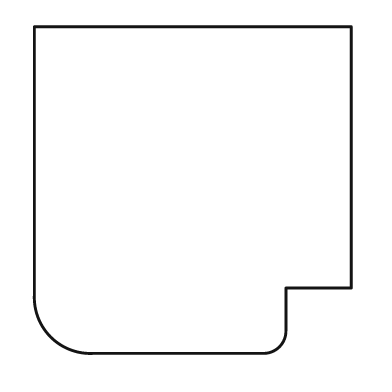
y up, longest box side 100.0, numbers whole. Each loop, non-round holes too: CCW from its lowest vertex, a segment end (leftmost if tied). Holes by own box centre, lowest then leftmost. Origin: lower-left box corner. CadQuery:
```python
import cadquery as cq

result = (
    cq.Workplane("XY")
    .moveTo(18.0, 0.0)
    .lineTo(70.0, 0.0)
    .threePointArc((75.0, 2.0), (77.0, 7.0))
    .lineTo(77.0, 20.0)
    .lineTo(97.0, 20.0)
    .lineTo(97.0, 100.0)
    .lineTo(0.0, 100.0)
    .lineTo(0.0, 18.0)
    .threePointArc((5.0, 5.0), (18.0, 0.0))
    .close()
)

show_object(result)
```